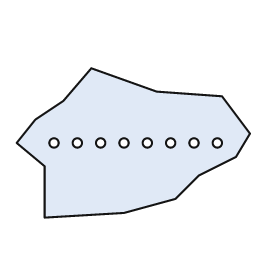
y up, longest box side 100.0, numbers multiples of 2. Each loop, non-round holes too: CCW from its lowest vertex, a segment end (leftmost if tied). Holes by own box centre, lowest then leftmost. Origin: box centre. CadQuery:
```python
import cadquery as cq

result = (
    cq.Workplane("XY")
    .moveTo(-38.0, -32.0)
    .lineTo(-4.0, -30.0)
    .lineTo(18.0, -24.0)
    .lineTo(28.0, -14.0)
    .lineTo(44.0, -6.0)
    .lineTo(50.0, 4.0)
    .lineTo(38.0, 20.0)
    .lineTo(10.0, 22.0)
    .lineTo(-18.0, 32.0)
    .lineTo(-30.0, 18.0)
    .lineTo(-42.0, 10.0)
    .lineTo(-50.0, 0.0)
    .lineTo(-38.0, -10.0)
    .close()
    .moveTo(-34.0, 0.0)
    .circle(2.0)
    .moveTo(-24.0, 0.0)
    .circle(2.0)
    .moveTo(-14.0, 0.0)
    .circle(2.0)
    .moveTo(-4.0, 0.0)
    .circle(2.0)
    .moveTo(6.0, 0.0)
    .circle(2.0)
    .moveTo(16.0, 0.0)
    .circle(2.0)
    .moveTo(26.0, 0.0)
    .circle(2.0)
    .moveTo(36.0, 0.0)
    .circle(2.0)
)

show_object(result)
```